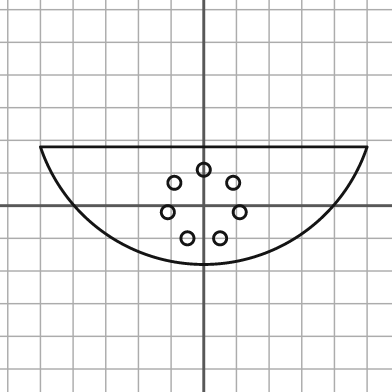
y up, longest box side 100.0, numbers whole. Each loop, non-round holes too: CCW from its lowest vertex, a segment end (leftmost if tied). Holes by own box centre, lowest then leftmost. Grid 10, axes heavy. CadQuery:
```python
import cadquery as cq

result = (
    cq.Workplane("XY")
    .moveTo(-50.0, 18.0)
    .threePointArc((0.0, -18.0), (50.0, 18.0))
    .close()
    .moveTo(-5.0, -10.0)
    .circle(2.0)
    .moveTo(5.0, -10.0)
    .circle(2.0)
    .moveTo(-11.0, -2.0)
    .circle(2.0)
    .moveTo(11.0, -2.0)
    .circle(2.0)
    .moveTo(-9.0, 7.0)
    .circle(2.0)
    .moveTo(9.0, 7.0)
    .circle(2.0)
    .moveTo(0.0, 11.0)
    .circle(2.0)
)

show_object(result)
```